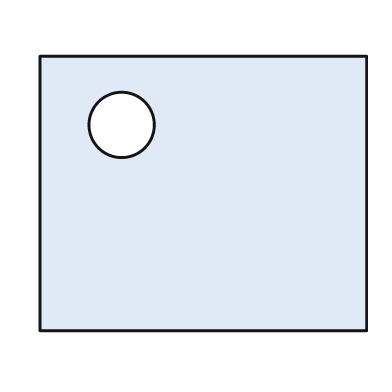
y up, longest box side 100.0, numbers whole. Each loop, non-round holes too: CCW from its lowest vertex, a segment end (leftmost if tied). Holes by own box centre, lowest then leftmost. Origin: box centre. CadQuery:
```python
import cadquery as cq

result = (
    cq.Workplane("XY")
    .moveTo(-50.0, -42.0)
    .lineTo(50.0, -42.0)
    .lineTo(50.0, 42.0)
    .lineTo(-50.0, 42.0)
    .close()
    .moveTo(-25.0, 21.0)
    .circle(10.0)
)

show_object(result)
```